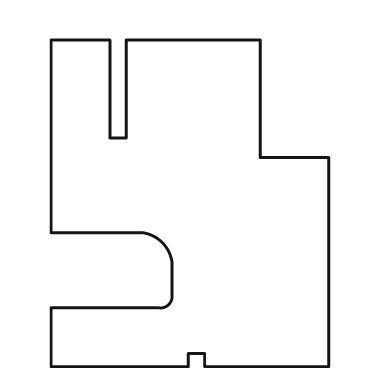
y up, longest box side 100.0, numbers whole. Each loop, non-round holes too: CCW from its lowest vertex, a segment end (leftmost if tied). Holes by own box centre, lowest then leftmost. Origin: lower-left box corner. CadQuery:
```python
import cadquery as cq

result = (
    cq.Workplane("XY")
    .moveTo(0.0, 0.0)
    .lineTo(42.0, 0.0)
    .lineTo(42.0, 4.0)
    .lineTo(47.0, 4.0)
    .lineTo(47.0, 0.0)
    .lineTo(85.0, 0.0)
    .lineTo(85.0, 64.0)
    .lineTo(64.0, 64.0)
    .lineTo(64.0, 100.0)
    .lineTo(23.0, 100.0)
    .lineTo(23.0, 70.0)
    .lineTo(18.0, 70.0)
    .lineTo(18.0, 100.0)
    .lineTo(0.0, 100.0)
    .lineTo(0.0, 41.0)
    .lineTo(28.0, 41.0)
    .threePointArc((34.0, 38.0), (37.0, 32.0))
    .lineTo(37.0, 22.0)
    .threePointArc((36.0, 19.0), (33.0, 18.0))
    .lineTo(0.0, 18.0)
    .close()
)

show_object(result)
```